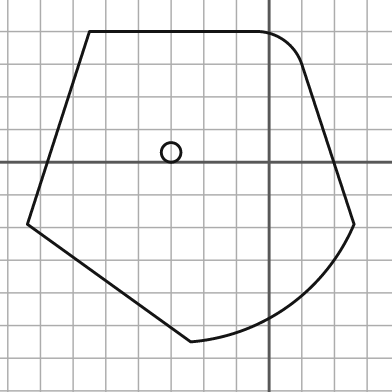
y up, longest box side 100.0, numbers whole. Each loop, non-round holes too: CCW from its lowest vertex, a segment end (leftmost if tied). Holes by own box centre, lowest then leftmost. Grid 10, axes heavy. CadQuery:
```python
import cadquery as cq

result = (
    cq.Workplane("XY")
    .moveTo(-24.0, -55.0)
    .threePointArc((6.0, -44.0), (26.0, -19.0))
    .lineTo(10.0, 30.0)
    .threePointArc((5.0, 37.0), (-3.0, 40.0))
    .lineTo(-55.0, 40.0)
    .lineTo(-74.0, -19.0)
    .close()
    .moveTo(-30.0, 3.0)
    .circle(3.0)
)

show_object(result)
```